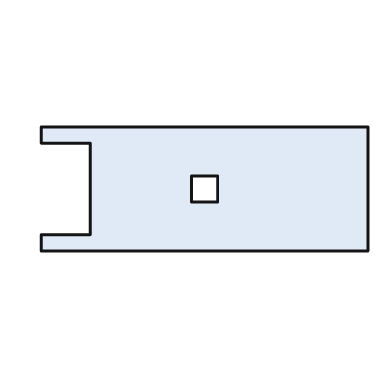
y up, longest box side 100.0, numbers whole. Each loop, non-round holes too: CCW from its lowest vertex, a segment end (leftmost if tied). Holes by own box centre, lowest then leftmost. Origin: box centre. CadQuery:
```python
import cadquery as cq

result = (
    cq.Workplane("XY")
    .moveTo(-50.0, -19.0)
    .lineTo(50.0, -19.0)
    .lineTo(50.0, 19.0)
    .lineTo(-50.0, 19.0)
    .lineTo(-50.0, 14.0)
    .lineTo(-35.0, 14.0)
    .lineTo(-35.0, -14.0)
    .lineTo(-50.0, -14.0)
    .close()
    .moveTo(-4.0, -4.0)
    .lineTo(4.0, -4.0)
    .lineTo(4.0, 4.0)
    .lineTo(-4.0, 4.0)
    .close()
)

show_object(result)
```